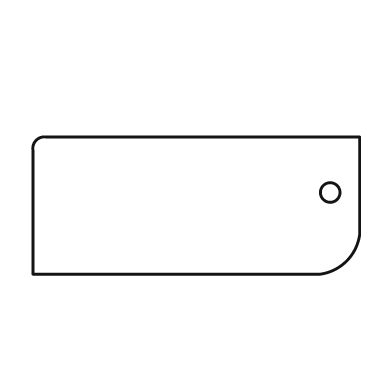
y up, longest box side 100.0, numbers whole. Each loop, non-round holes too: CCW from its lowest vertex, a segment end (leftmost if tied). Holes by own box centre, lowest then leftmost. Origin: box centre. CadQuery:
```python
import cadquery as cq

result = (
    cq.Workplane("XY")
    .moveTo(-50.0, -21.0)
    .lineTo(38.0, -21.0)
    .threePointArc((46.0, -17.0), (50.0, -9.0))
    .lineTo(50.0, 21.0)
    .lineTo(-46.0, 21.0)
    .threePointArc((-49.0, 20.0), (-50.0, 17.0))
    .close()
    .moveTo(41.0, 4.0)
    .circle(3.0)
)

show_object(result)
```